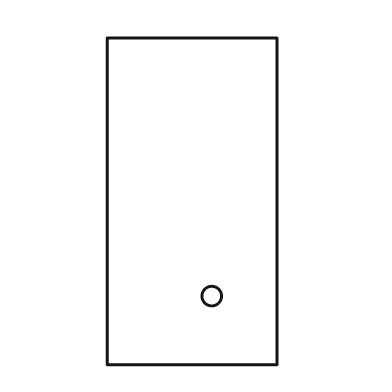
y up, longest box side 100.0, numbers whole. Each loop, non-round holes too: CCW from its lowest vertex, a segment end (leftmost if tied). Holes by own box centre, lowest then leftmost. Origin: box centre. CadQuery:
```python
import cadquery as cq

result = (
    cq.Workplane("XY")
    .moveTo(-26.0, -50.0)
    .lineTo(26.0, -50.0)
    .lineTo(26.0, 50.0)
    .lineTo(-26.0, 50.0)
    .close()
    .moveTo(6.0, -29.0)
    .circle(3.0)
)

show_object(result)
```